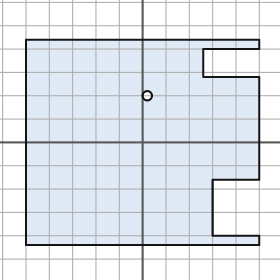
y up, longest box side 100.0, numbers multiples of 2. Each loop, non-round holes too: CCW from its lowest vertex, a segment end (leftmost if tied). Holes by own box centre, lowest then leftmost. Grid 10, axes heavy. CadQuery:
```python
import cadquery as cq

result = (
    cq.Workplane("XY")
    .moveTo(-50.0, -44.0)
    .lineTo(50.0, -44.0)
    .lineTo(50.0, -40.0)
    .lineTo(30.0, -40.0)
    .lineTo(30.0, -16.0)
    .lineTo(50.0, -16.0)
    .lineTo(50.0, 28.0)
    .lineTo(26.0, 28.0)
    .lineTo(26.0, 40.0)
    .lineTo(50.0, 40.0)
    .lineTo(50.0, 44.0)
    .lineTo(-50.0, 44.0)
    .close()
    .moveTo(2.0, 20.0)
    .circle(2.0)
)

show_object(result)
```